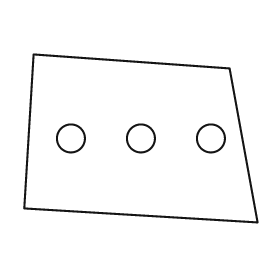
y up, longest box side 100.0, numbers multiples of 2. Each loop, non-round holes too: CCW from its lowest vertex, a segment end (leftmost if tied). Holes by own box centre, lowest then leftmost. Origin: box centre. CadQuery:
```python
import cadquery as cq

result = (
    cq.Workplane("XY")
    .moveTo(50.0, -36.0)
    .lineTo(38.0, 30.0)
    .lineTo(-46.0, 36.0)
    .lineTo(-50.0, -30.0)
    .close()
    .moveTo(-30.0, 0.0)
    .circle(6.0)
    .moveTo(0.0, 0.0)
    .circle(6.0)
    .moveTo(30.0, 0.0)
    .circle(6.0)
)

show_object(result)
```